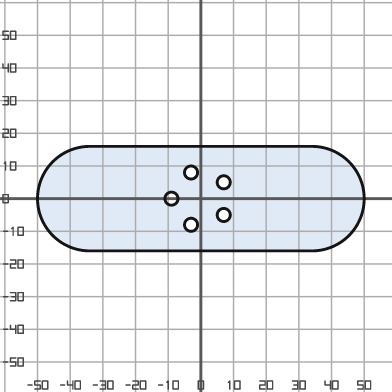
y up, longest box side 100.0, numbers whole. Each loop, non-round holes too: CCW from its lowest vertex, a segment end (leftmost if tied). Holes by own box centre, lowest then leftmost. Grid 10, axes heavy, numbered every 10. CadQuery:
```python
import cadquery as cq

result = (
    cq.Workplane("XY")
    .moveTo(-34.0, -16.0)
    .lineTo(34.0, -16.0)
    .threePointArc((50.0, 0.0), (34.0, 16.0))
    .lineTo(-34.0, 16.0)
    .threePointArc((-50.0, 0.0), (-34.0, -16.0))
    .close()
    .moveTo(-3.0, -8.0)
    .circle(2.0)
    .moveTo(7.0, -5.0)
    .circle(2.0)
    .moveTo(-9.0, 0.0)
    .circle(2.0)
    .moveTo(7.0, 5.0)
    .circle(2.0)
    .moveTo(-3.0, 8.0)
    .circle(2.0)
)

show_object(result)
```